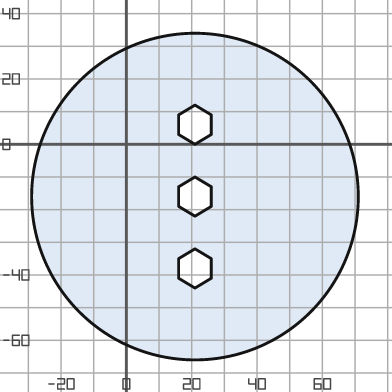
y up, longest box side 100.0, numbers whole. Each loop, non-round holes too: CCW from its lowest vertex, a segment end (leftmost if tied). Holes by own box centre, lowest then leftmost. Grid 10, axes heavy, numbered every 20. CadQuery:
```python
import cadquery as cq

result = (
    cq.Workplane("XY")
    .moveTo(21.0, -16.0)
    .circle(50.0)
    .moveTo(21.0, -44.0)
    .lineTo(26.0, -41.0)
    .lineTo(26.0, -35.0)
    .lineTo(21.0, -32.0)
    .lineTo(16.0, -35.0)
    .lineTo(16.0, -41.0)
    .close()
    .moveTo(21.0, -22.0)
    .lineTo(26.0, -19.0)
    .lineTo(26.0, -13.0)
    .lineTo(21.0, -10.0)
    .lineTo(16.0, -13.0)
    .lineTo(16.0, -19.0)
    .close()
    .moveTo(21.0, 0.0)
    .lineTo(26.0, 3.0)
    .lineTo(26.0, 9.0)
    .lineTo(21.0, 12.0)
    .lineTo(16.0, 9.0)
    .lineTo(16.0, 3.0)
    .close()
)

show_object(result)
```